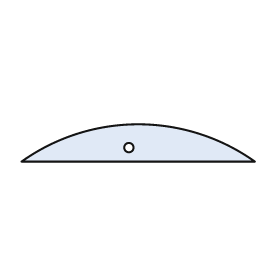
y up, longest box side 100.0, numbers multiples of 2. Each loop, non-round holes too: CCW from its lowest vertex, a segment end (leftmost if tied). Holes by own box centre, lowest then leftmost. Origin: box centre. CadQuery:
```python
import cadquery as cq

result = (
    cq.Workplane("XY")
    .moveTo(-50.0, -8.0)
    .lineTo(50.0, -8.0)
    .threePointArc((0.0, 8.0), (-50.0, -8.0))
    .close()
    .moveTo(-4.0, -2.0)
    .circle(2.0)
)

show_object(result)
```